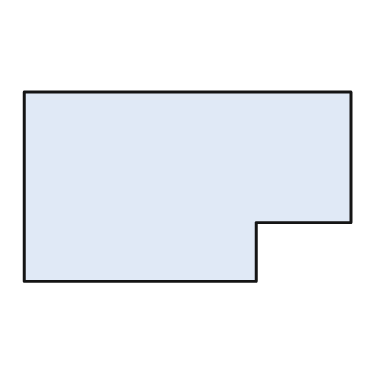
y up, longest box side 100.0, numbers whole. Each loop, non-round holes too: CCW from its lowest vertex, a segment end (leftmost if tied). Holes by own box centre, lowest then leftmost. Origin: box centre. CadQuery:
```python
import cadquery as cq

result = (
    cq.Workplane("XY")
    .moveTo(-50.0, -29.0)
    .lineTo(21.0, -29.0)
    .lineTo(21.0, -11.0)
    .lineTo(50.0, -11.0)
    .lineTo(50.0, 29.0)
    .lineTo(-50.0, 29.0)
    .close()
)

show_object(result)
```